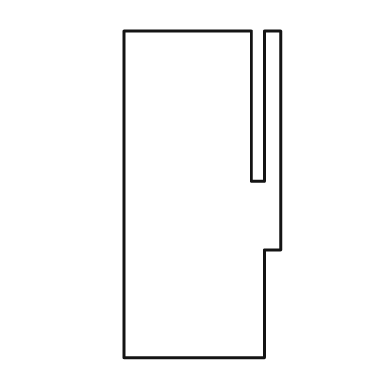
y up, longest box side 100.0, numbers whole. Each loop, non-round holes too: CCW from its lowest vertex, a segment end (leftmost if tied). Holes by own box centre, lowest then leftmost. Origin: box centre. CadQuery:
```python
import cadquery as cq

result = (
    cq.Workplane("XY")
    .moveTo(-24.0, -50.0)
    .lineTo(19.0, -50.0)
    .lineTo(19.0, -17.0)
    .lineTo(24.0, -17.0)
    .lineTo(24.0, 50.0)
    .lineTo(19.0, 50.0)
    .lineTo(19.0, 4.0)
    .lineTo(15.0, 4.0)
    .lineTo(15.0, 50.0)
    .lineTo(-24.0, 50.0)
    .close()
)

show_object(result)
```